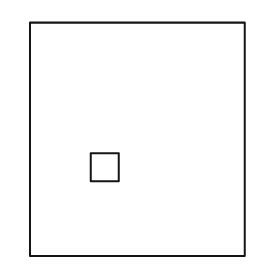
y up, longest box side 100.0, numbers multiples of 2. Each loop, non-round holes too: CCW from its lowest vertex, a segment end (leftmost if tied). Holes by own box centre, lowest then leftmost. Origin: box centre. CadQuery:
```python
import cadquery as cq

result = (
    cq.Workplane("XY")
    .moveTo(-46.0, -50.0)
    .lineTo(46.0, -50.0)
    .lineTo(46.0, 50.0)
    .lineTo(-46.0, 50.0)
    .close()
    .moveTo(-20.0, -18.0)
    .lineTo(-8.0, -18.0)
    .lineTo(-8.0, -6.0)
    .lineTo(-20.0, -6.0)
    .close()
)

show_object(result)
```